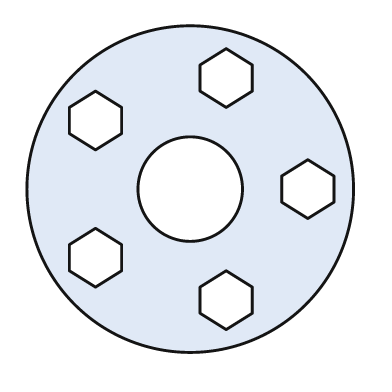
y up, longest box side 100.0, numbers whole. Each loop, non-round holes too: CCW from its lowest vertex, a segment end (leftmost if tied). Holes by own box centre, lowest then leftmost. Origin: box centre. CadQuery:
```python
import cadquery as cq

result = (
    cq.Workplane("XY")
    .moveTo(0.0, 0.0)
    .circle(50.0)
    .moveTo(11.0, -43.0)
    .lineTo(19.0, -38.0)
    .lineTo(19.0, -30.0)
    .lineTo(11.0, -25.0)
    .lineTo(3.0, -30.0)
    .lineTo(3.0, -38.0)
    .close()
    .moveTo(-29.0, -30.0)
    .lineTo(-21.0, -25.0)
    .lineTo(-21.0, -17.0)
    .lineTo(-29.0, -12.0)
    .lineTo(-37.0, -17.0)
    .lineTo(-37.0, -25.0)
    .close()
    .moveTo(0.0, 0.0)
    .circle(16.0)
    .moveTo(36.0, -9.0)
    .lineTo(44.0, -4.0)
    .lineTo(44.0, 4.0)
    .lineTo(36.0, 9.0)
    .lineTo(28.0, 4.0)
    .lineTo(28.0, -4.0)
    .close()
    .moveTo(-29.0, 12.0)
    .lineTo(-21.0, 17.0)
    .lineTo(-21.0, 25.0)
    .lineTo(-29.0, 30.0)
    .lineTo(-37.0, 25.0)
    .lineTo(-37.0, 17.0)
    .close()
    .moveTo(11.0, 25.0)
    .lineTo(19.0, 30.0)
    .lineTo(19.0, 38.0)
    .lineTo(11.0, 43.0)
    .lineTo(3.0, 38.0)
    .lineTo(3.0, 30.0)
    .close()
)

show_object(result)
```